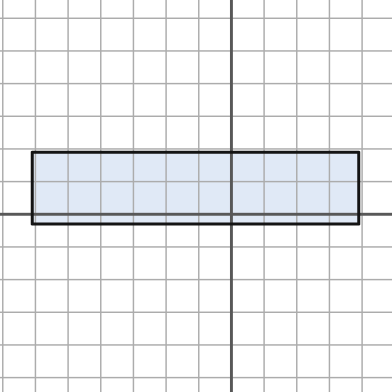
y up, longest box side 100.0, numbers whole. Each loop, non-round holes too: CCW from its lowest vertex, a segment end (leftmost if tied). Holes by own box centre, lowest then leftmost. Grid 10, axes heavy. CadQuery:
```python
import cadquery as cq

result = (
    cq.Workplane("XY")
    .moveTo(-61.0, -3.0)
    .lineTo(39.0, -3.0)
    .lineTo(39.0, 19.0)
    .lineTo(-61.0, 19.0)
    .close()
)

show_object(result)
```